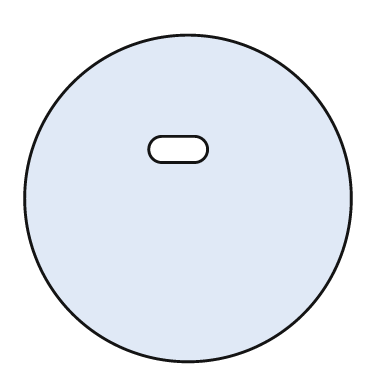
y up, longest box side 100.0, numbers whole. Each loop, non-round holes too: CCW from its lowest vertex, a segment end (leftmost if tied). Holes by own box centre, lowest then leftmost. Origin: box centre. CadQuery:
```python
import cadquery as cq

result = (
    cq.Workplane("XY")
    .moveTo(0.0, 0.0)
    .circle(50.0)
    .moveTo(-8.0, 11.0)
    .lineTo(2.0, 11.0)
    .threePointArc((6.0, 15.0), (2.0, 19.0))
    .lineTo(-8.0, 19.0)
    .threePointArc((-12.0, 15.0), (-8.0, 11.0))
    .close()
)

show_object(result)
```